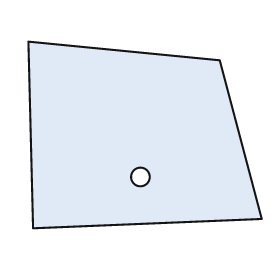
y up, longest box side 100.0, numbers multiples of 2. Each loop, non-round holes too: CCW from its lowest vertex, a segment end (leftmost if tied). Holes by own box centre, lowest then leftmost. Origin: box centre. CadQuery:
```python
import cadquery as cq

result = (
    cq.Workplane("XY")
    .moveTo(-48.0, -40.0)
    .lineTo(50.0, -36.0)
    .lineTo(32.0, 32.0)
    .lineTo(-50.0, 40.0)
    .close()
    .moveTo(-2.0, -18.0)
    .circle(4.0)
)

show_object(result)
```